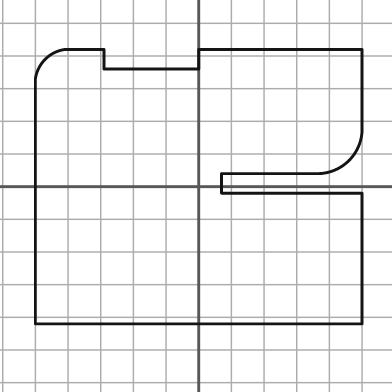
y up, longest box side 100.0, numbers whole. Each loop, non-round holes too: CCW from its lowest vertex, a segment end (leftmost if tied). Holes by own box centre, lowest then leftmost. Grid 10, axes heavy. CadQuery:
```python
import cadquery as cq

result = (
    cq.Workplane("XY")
    .moveTo(-50.0, -42.0)
    .lineTo(50.0, -42.0)
    .lineTo(50.0, -2.0)
    .lineTo(7.0, -2.0)
    .lineTo(7.0, 4.0)
    .lineTo(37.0, 4.0)
    .threePointArc((46.0, 8.0), (50.0, 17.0))
    .lineTo(50.0, 42.0)
    .lineTo(0.0, 42.0)
    .lineTo(0.0, 36.0)
    .lineTo(-29.0, 36.0)
    .lineTo(-29.0, 42.0)
    .lineTo(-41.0, 42.0)
    .threePointArc((-47.0, 39.0), (-50.0, 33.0))
    .close()
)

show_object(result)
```